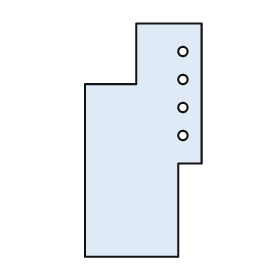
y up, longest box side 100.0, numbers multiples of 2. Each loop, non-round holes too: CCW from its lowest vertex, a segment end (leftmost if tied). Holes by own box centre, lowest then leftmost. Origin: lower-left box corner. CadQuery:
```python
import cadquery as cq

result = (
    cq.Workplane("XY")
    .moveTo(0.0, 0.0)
    .lineTo(40.0, 0.0)
    .lineTo(40.0, 40.0)
    .lineTo(50.0, 40.0)
    .lineTo(50.0, 100.0)
    .lineTo(22.0, 100.0)
    .lineTo(22.0, 74.0)
    .lineTo(0.0, 74.0)
    .close()
    .moveTo(42.0, 52.0)
    .circle(2.0)
    .moveTo(42.0, 64.0)
    .circle(2.0)
    .moveTo(42.0, 76.0)
    .circle(2.0)
    .moveTo(42.0, 88.0)
    .circle(2.0)
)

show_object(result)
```